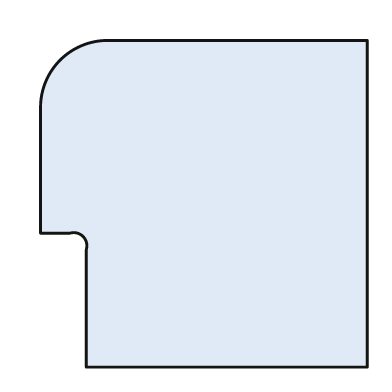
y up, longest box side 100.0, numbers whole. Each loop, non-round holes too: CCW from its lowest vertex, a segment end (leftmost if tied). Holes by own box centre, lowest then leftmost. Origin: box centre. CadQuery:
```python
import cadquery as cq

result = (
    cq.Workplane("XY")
    .moveTo(-36.0, -50.0)
    .lineTo(50.0, -50.0)
    .lineTo(50.0, 50.0)
    .lineTo(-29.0, 50.0)
    .threePointArc((-44.0, 44.0), (-50.0, 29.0))
    .lineTo(-50.0, -9.0)
    .lineTo(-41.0, -9.0)
    .threePointArc((-37.0, -10.0), (-36.0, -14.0))
    .close()
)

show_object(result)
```